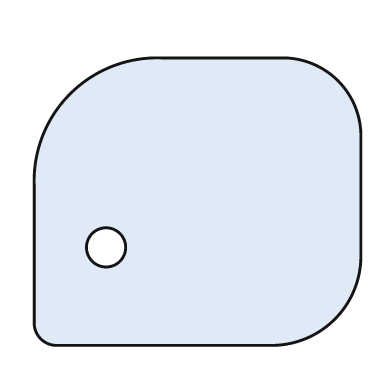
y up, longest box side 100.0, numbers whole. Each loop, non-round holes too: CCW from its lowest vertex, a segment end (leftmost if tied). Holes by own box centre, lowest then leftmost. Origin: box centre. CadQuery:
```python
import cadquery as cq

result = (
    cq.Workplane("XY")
    .moveTo(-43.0, -44.0)
    .lineTo(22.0, -44.0)
    .threePointArc((42.0, -36.0), (50.0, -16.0))
    .lineTo(50.0, 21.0)
    .threePointArc((43.0, 37.0), (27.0, 44.0))
    .lineTo(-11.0, 44.0)
    .threePointArc((-39.0, 33.0), (-50.0, 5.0))
    .lineTo(-50.0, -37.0)
    .threePointArc((-48.0, -42.0), (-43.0, -44.0))
    .close()
    .moveTo(-28.0, -14.0)
    .circle(6.0)
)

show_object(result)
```